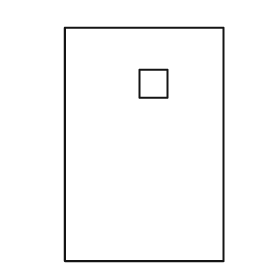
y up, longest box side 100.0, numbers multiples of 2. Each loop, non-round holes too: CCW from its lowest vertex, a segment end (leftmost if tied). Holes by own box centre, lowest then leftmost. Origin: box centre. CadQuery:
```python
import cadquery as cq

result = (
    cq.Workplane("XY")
    .moveTo(-34.0, -50.0)
    .lineTo(34.0, -50.0)
    .lineTo(34.0, 50.0)
    .lineTo(-34.0, 50.0)
    .close()
    .moveTo(-2.0, 20.0)
    .lineTo(10.0, 20.0)
    .lineTo(10.0, 32.0)
    .lineTo(-2.0, 32.0)
    .close()
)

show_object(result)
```